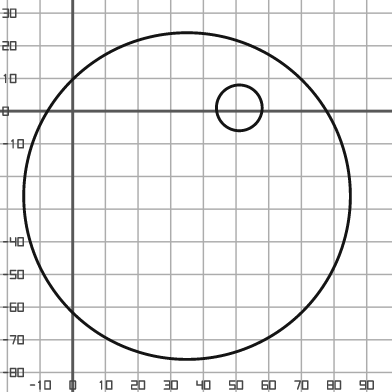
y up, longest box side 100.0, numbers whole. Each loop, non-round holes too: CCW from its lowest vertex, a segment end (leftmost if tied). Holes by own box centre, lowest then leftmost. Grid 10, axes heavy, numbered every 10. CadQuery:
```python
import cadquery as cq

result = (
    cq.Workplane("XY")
    .moveTo(35.0, -26.0)
    .circle(50.0)
    .moveTo(51.0, 1.0)
    .circle(7.0)
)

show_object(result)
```